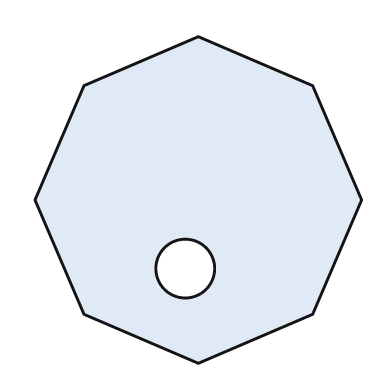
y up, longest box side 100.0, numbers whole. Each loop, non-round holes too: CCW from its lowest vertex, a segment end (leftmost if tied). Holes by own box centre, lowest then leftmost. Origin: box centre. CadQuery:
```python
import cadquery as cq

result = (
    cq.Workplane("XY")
    .moveTo(0.0, -50.0)
    .lineTo(35.0, -35.0)
    .lineTo(50.0, 0.0)
    .lineTo(35.0, 35.0)
    .lineTo(0.0, 50.0)
    .lineTo(-35.0, 35.0)
    .lineTo(-50.0, 0.0)
    .lineTo(-35.0, -35.0)
    .close()
    .moveTo(-4.0, -21.0)
    .circle(9.0)
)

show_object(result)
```